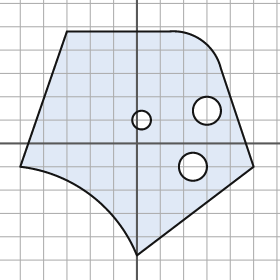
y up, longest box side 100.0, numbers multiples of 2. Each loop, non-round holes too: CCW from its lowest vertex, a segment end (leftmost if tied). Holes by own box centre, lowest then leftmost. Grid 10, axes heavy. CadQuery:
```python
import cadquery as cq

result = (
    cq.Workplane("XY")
    .moveTo(0.0, -48.0)
    .lineTo(50.0, -10.0)
    .lineTo(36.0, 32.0)
    .threePointArc((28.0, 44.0), (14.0, 48.0))
    .lineTo(-30.0, 48.0)
    .lineTo(-50.0, -10.0)
    .threePointArc((-20.0, -22.0), (0.0, -48.0))
    .close()
    .moveTo(24.0, -10.0)
    .circle(6.0)
    .moveTo(2.0, 10.0)
    .circle(4.0)
    .moveTo(30.0, 14.0)
    .circle(6.0)
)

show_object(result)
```